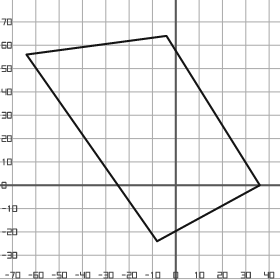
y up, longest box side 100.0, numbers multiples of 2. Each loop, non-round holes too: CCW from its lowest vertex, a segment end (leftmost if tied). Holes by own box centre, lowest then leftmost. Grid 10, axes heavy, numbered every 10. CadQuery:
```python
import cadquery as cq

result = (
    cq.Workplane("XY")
    .moveTo(-8.0, -24.0)
    .lineTo(36.0, 0.0)
    .lineTo(-4.0, 64.0)
    .lineTo(-64.0, 56.0)
    .close()
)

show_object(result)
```